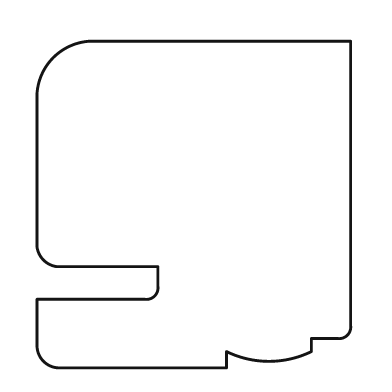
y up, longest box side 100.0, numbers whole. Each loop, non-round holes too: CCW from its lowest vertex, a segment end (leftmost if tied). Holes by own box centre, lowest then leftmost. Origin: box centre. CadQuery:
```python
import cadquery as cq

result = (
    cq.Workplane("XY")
    .moveTo(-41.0, -50.0)
    .lineTo(10.0, -50.0)
    .lineTo(10.0, -45.0)
    .threePointArc((23.0, -48.0), (36.0, -45.0))
    .lineTo(36.0, -41.0)
    .lineTo(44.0, -41.0)
    .threePointArc((47.0, -40.0), (48.0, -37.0))
    .lineTo(48.0, 50.0)
    .lineTo(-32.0, 50.0)
    .threePointArc((-43.0, 45.0), (-48.0, 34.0))
    .lineTo(-48.0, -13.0)
    .threePointArc((-46.0, -17.0), (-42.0, -19.0))
    .lineTo(-11.0, -19.0)
    .lineTo(-11.0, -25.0)
    .threePointArc((-12.0, -28.0), (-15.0, -29.0))
    .lineTo(-48.0, -29.0)
    .lineTo(-48.0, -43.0)
    .threePointArc((-46.0, -48.0), (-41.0, -50.0))
    .close()
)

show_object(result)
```